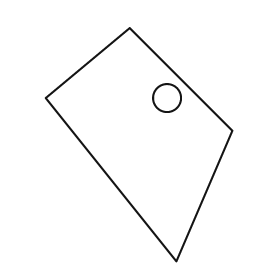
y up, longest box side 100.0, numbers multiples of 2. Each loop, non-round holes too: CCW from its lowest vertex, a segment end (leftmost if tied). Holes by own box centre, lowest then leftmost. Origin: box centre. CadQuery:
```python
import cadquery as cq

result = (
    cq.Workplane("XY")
    .moveTo(16.0, -50.0)
    .lineTo(40.0, 6.0)
    .lineTo(-4.0, 50.0)
    .lineTo(-40.0, 20.0)
    .close()
    .moveTo(12.0, 20.0)
    .circle(6.0)
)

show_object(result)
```